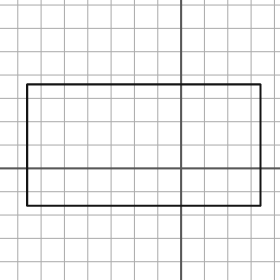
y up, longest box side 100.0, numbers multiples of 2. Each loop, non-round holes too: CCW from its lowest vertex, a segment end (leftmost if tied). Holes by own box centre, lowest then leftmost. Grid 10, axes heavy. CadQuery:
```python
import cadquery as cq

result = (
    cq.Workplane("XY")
    .moveTo(-66.0, -16.0)
    .lineTo(34.0, -16.0)
    .lineTo(34.0, 36.0)
    .lineTo(-66.0, 36.0)
    .close()
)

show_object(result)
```